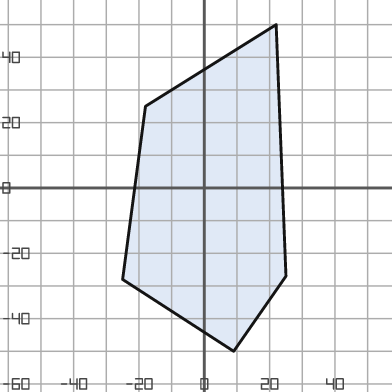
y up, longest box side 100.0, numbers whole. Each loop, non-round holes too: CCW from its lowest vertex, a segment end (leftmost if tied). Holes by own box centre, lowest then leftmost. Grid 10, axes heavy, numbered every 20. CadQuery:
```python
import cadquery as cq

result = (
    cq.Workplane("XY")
    .moveTo(9.0, -50.0)
    .lineTo(25.0, -27.0)
    .lineTo(22.0, 50.0)
    .lineTo(-18.0, 25.0)
    .lineTo(-25.0, -28.0)
    .close()
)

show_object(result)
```